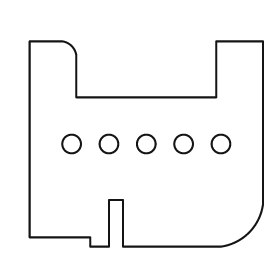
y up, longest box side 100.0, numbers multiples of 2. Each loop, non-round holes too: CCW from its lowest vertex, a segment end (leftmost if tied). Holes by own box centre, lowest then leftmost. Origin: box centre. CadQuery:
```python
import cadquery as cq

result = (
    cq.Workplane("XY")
    .moveTo(-24.0, -44.0)
    .lineTo(-16.0, -44.0)
    .lineTo(-16.0, -24.0)
    .lineTo(-10.0, -24.0)
    .lineTo(-10.0, -44.0)
    .lineTo(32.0, -44.0)
    .threePointArc((44.0, -38.0), (50.0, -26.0))
    .lineTo(50.0, 44.0)
    .lineTo(30.0, 44.0)
    .lineTo(30.0, 20.0)
    .lineTo(-30.0, 20.0)
    .lineTo(-30.0, 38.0)
    .threePointArc((-32.0, 42.0), (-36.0, 44.0))
    .lineTo(-50.0, 44.0)
    .lineTo(-50.0, -40.0)
    .lineTo(-24.0, -40.0)
    .close()
    .moveTo(-32.0, 0.0)
    .circle(4.0)
    .moveTo(-16.0, 0.0)
    .circle(4.0)
    .moveTo(0.0, 0.0)
    .circle(4.0)
    .moveTo(16.0, 0.0)
    .circle(4.0)
    .moveTo(32.0, 0.0)
    .circle(4.0)
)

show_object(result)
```